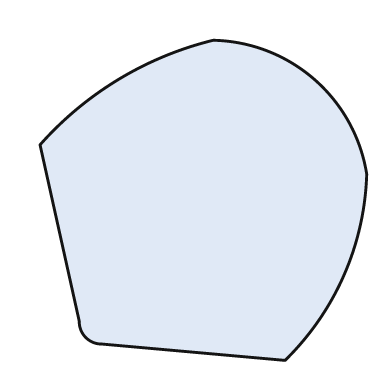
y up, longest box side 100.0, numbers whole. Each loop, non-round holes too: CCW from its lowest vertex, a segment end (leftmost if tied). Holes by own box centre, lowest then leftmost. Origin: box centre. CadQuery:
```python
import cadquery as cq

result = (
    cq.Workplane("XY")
    .moveTo(25.0, -49.0)
    .threePointArc((43.0, -23.0), (50.0, 8.0))
    .threePointArc((34.0, 37.0), (3.0, 49.0))
    .threePointArc((-26.0, 37.0), (-50.0, 17.0))
    .lineTo(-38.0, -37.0)
    .threePointArc((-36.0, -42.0), (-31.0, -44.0))
    .close()
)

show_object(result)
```